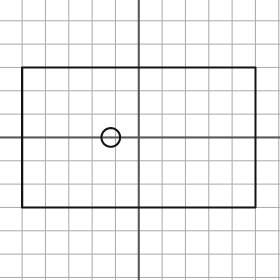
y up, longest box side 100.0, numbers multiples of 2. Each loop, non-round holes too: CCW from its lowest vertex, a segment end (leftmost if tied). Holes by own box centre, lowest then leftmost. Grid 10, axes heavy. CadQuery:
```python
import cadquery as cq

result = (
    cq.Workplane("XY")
    .moveTo(-50.0, -30.0)
    .lineTo(50.0, -30.0)
    .lineTo(50.0, 30.0)
    .lineTo(-50.0, 30.0)
    .close()
    .moveTo(-12.0, 0.0)
    .circle(4.0)
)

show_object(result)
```